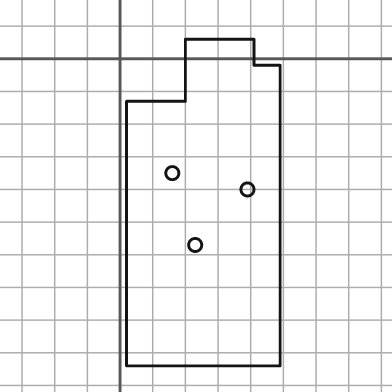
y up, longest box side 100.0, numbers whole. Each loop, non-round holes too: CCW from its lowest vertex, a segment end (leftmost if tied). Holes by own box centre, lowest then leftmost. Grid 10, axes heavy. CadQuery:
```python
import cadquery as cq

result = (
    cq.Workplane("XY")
    .moveTo(2.0, -94.0)
    .lineTo(49.0, -94.0)
    .lineTo(49.0, -2.0)
    .lineTo(41.0, -2.0)
    .lineTo(41.0, 6.0)
    .lineTo(20.0, 6.0)
    .lineTo(20.0, -13.0)
    .lineTo(2.0, -13.0)
    .close()
    .moveTo(23.0, -57.0)
    .circle(2.0)
    .moveTo(39.0, -40.0)
    .circle(2.0)
    .moveTo(16.0, -35.0)
    .circle(2.0)
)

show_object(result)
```